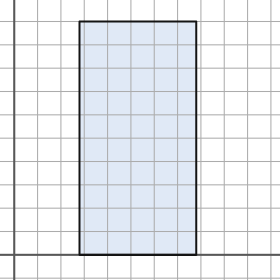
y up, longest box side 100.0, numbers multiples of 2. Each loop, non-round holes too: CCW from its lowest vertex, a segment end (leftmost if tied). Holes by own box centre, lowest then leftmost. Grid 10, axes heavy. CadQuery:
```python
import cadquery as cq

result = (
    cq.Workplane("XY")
    .moveTo(28.0, 0.0)
    .lineTo(78.0, 0.0)
    .lineTo(78.0, 100.0)
    .lineTo(28.0, 100.0)
    .close()
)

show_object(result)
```